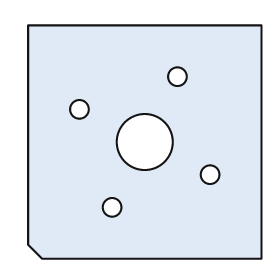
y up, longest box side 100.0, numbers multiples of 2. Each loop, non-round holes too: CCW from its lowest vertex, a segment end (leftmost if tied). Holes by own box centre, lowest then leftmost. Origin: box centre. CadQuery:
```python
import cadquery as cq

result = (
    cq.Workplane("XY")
    .moveTo(-44.0, -50.0)
    .lineTo(50.0, -50.0)
    .lineTo(50.0, 50.0)
    .lineTo(-50.0, 50.0)
    .lineTo(-50.0, -44.0)
    .close()
    .moveTo(-14.0, -28.0)
    .circle(4.0)
    .moveTo(28.0, -14.0)
    .circle(4.0)
    .moveTo(0.0, 0.0)
    .circle(12.0)
    .moveTo(-28.0, 14.0)
    .circle(4.0)
    .moveTo(14.0, 28.0)
    .circle(4.0)
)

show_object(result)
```